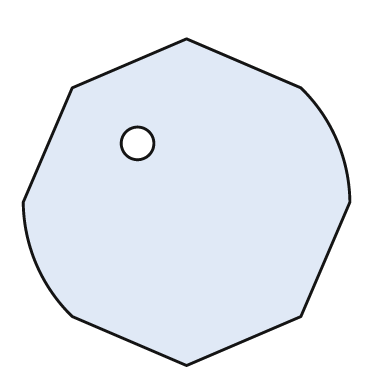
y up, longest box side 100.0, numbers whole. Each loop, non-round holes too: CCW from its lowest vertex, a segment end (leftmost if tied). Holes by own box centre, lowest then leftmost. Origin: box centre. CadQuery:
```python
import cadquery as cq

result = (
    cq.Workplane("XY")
    .moveTo(0.0, -50.0)
    .lineTo(35.0, -35.0)
    .lineTo(50.0, 0.0)
    .threePointArc((46.0, 19.0), (35.0, 35.0))
    .lineTo(0.0, 50.0)
    .lineTo(-35.0, 35.0)
    .lineTo(-50.0, 0.0)
    .threePointArc((-46.0, -19.0), (-35.0, -35.0))
    .close()
    .moveTo(-15.0, 18.0)
    .circle(5.0)
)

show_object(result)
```